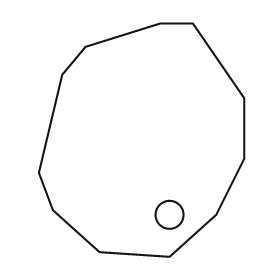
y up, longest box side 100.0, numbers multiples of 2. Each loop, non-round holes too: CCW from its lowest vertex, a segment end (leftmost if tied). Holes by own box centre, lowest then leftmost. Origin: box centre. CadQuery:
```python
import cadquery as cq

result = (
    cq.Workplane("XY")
    .moveTo(12.0, -50.0)
    .lineTo(32.0, -32.0)
    .lineTo(44.0, -8.0)
    .lineTo(44.0, 18.0)
    .lineTo(22.0, 50.0)
    .lineTo(8.0, 50.0)
    .lineTo(-24.0, 40.0)
    .lineTo(-34.0, 28.0)
    .lineTo(-44.0, -14.0)
    .lineTo(-38.0, -30.0)
    .lineTo(-18.0, -48.0)
    .close()
    .moveTo(12.0, -32.0)
    .circle(6.0)
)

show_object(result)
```